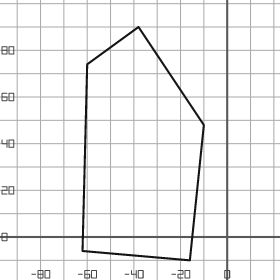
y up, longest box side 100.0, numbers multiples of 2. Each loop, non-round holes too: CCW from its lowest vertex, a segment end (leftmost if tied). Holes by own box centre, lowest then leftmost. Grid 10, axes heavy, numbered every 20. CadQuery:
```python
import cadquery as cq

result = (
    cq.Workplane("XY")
    .moveTo(-16.0, -10.0)
    .lineTo(-10.0, 48.0)
    .lineTo(-38.0, 90.0)
    .lineTo(-60.0, 74.0)
    .lineTo(-62.0, -6.0)
    .close()
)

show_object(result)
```